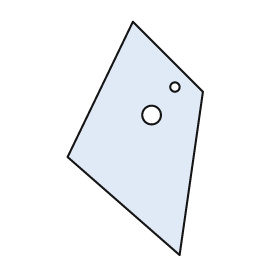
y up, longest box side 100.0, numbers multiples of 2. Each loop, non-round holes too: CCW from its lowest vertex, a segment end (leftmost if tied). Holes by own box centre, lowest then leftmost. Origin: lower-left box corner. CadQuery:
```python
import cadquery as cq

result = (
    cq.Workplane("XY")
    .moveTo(48.0, 0.0)
    .lineTo(58.0, 70.0)
    .lineTo(28.0, 100.0)
    .lineTo(0.0, 42.0)
    .close()
    .moveTo(36.0, 60.0)
    .circle(4.0)
    .moveTo(46.0, 72.0)
    .circle(2.0)
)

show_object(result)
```